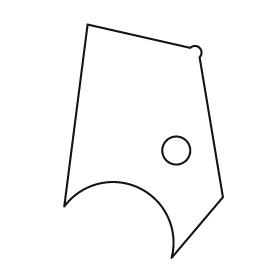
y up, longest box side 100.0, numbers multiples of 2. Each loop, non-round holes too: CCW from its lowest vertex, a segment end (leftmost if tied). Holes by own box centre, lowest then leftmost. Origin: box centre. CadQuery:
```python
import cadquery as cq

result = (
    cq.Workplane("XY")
    .moveTo(12.0, -50.0)
    .lineTo(34.0, -24.0)
    .lineTo(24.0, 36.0)
    .threePointArc((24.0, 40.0), (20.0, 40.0))
    .lineTo(-24.0, 50.0)
    .lineTo(-34.0, -28.0)
    .threePointArc((-2.0, -20.0), (12.0, -50.0))
    .close()
    .moveTo(14.0, -4.0)
    .circle(6.0)
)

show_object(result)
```